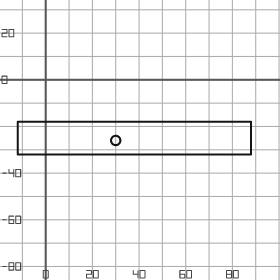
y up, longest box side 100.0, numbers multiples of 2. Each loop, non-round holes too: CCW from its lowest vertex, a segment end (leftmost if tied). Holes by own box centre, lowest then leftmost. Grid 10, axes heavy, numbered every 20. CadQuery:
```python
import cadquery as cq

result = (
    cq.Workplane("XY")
    .moveTo(-12.0, -32.0)
    .lineTo(88.0, -32.0)
    .lineTo(88.0, -18.0)
    .lineTo(-12.0, -18.0)
    .close()
    .moveTo(30.0, -26.0)
    .circle(2.0)
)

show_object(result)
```